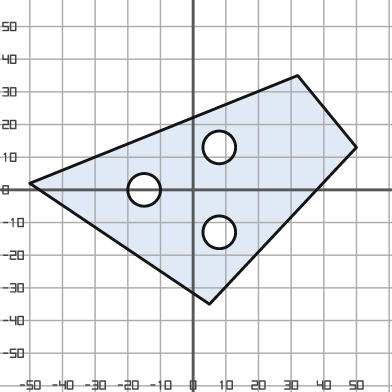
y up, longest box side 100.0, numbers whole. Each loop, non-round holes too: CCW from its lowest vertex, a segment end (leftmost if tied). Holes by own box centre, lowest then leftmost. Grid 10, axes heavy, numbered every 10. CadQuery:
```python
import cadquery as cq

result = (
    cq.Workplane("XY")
    .moveTo(5.0, -35.0)
    .lineTo(50.0, 13.0)
    .lineTo(32.0, 35.0)
    .lineTo(-50.0, 2.0)
    .close()
    .moveTo(8.0, -13.0)
    .circle(5.0)
    .moveTo(-15.0, 0.0)
    .circle(5.0)
    .moveTo(8.0, 13.0)
    .circle(5.0)
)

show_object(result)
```